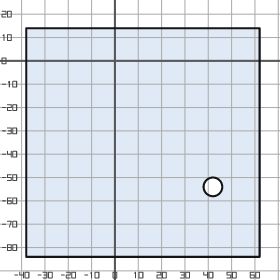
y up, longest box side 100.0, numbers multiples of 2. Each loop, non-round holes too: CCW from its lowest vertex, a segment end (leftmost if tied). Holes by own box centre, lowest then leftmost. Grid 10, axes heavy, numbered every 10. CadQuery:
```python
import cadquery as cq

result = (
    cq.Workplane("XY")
    .moveTo(-38.0, -84.0)
    .lineTo(62.0, -84.0)
    .lineTo(62.0, 14.0)
    .lineTo(-38.0, 14.0)
    .close()
    .moveTo(42.0, -54.0)
    .circle(4.0)
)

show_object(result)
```